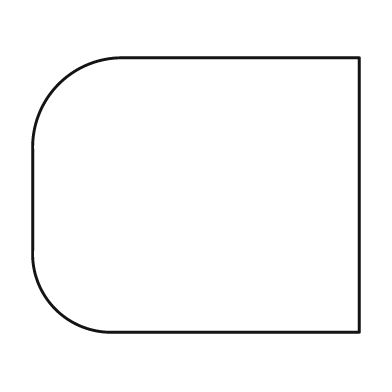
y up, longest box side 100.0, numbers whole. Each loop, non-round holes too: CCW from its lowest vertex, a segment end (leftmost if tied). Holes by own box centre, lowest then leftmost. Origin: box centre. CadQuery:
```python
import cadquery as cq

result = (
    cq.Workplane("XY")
    .moveTo(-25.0, -42.0)
    .lineTo(50.0, -42.0)
    .lineTo(50.0, 42.0)
    .lineTo(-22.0, 42.0)
    .threePointArc((-42.0, 34.0), (-50.0, 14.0))
    .lineTo(-50.0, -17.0)
    .threePointArc((-43.0, -35.0), (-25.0, -42.0))
    .close()
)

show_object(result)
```